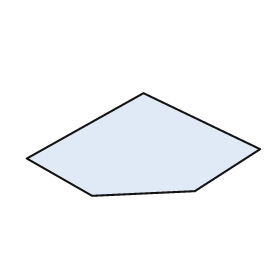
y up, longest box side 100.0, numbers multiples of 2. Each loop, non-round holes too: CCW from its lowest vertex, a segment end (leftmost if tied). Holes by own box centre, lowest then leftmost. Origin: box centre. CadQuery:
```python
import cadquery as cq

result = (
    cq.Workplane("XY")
    .moveTo(-22.0, -22.0)
    .lineTo(22.0, -20.0)
    .lineTo(50.0, -2.0)
    .lineTo(0.0, 22.0)
    .lineTo(-50.0, -6.0)
    .close()
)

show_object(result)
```